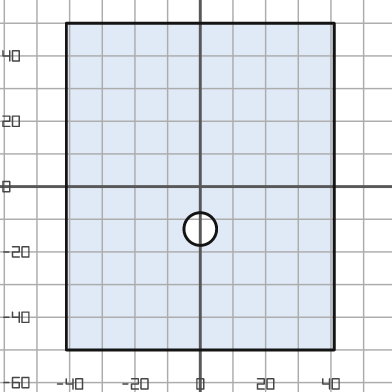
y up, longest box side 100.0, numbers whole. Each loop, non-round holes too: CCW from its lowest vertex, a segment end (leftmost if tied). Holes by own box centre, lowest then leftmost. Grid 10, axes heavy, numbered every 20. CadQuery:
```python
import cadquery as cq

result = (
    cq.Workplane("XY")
    .moveTo(-41.0, -50.0)
    .lineTo(41.0, -50.0)
    .lineTo(41.0, 50.0)
    .lineTo(-41.0, 50.0)
    .close()
    .moveTo(0.0, -13.0)
    .circle(5.0)
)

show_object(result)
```